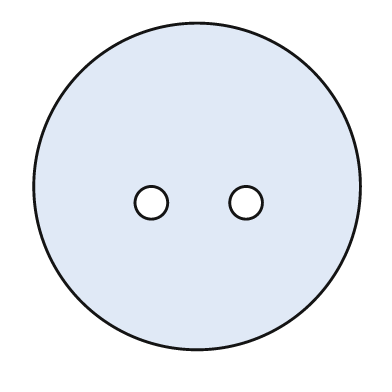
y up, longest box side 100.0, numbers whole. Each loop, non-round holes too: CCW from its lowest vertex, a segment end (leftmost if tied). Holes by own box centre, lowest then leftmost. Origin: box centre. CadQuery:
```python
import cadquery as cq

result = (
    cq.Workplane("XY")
    .moveTo(0.0, 0.0)
    .circle(50.0)
    .moveTo(-14.0, -5.0)
    .circle(5.0)
    .moveTo(15.0, -5.0)
    .circle(5.0)
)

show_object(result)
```